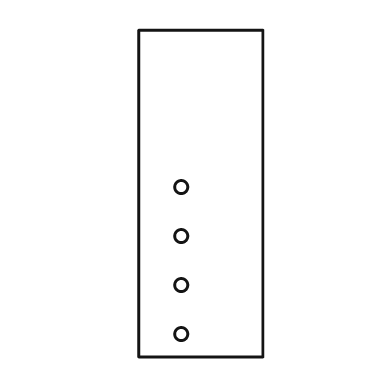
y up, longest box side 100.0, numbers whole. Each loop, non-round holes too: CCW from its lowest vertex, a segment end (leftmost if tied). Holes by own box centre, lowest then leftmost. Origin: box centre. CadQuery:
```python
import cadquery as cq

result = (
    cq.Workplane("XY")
    .moveTo(-19.0, -50.0)
    .lineTo(19.0, -50.0)
    .lineTo(19.0, 50.0)
    .lineTo(-19.0, 50.0)
    .close()
    .moveTo(-6.0, -43.0)
    .circle(2.0)
    .moveTo(-6.0, -28.0)
    .circle(2.0)
    .moveTo(-6.0, -13.0)
    .circle(2.0)
    .moveTo(-6.0, 2.0)
    .circle(2.0)
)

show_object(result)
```